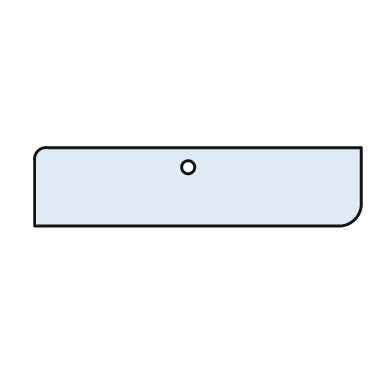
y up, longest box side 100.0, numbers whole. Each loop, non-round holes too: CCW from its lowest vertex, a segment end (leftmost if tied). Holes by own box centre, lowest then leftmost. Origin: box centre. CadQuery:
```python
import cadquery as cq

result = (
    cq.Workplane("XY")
    .moveTo(-50.0, -12.0)
    .lineTo(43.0, -12.0)
    .threePointArc((48.0, -10.0), (50.0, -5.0))
    .lineTo(50.0, 12.0)
    .lineTo(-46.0, 12.0)
    .threePointArc((-49.0, 11.0), (-50.0, 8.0))
    .close()
    .moveTo(-3.0, 6.0)
    .circle(2.0)
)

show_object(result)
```